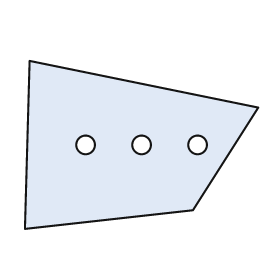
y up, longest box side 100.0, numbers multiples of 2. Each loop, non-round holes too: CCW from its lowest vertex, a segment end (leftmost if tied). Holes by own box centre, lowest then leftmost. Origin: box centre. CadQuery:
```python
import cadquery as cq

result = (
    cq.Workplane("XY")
    .moveTo(-50.0, -36.0)
    .lineTo(22.0, -28.0)
    .lineTo(50.0, 16.0)
    .lineTo(-48.0, 36.0)
    .close()
    .moveTo(-24.0, 0.0)
    .circle(4.0)
    .moveTo(0.0, 0.0)
    .circle(4.0)
    .moveTo(24.0, 0.0)
    .circle(4.0)
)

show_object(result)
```